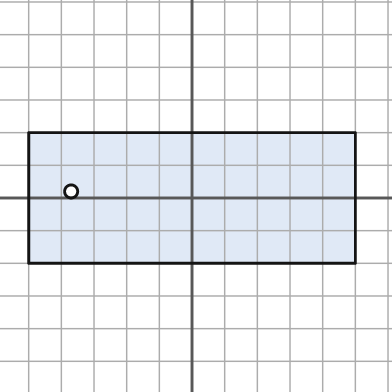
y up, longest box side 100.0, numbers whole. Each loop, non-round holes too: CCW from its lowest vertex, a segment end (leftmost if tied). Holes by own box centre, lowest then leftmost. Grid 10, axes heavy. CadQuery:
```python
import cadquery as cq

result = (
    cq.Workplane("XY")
    .moveTo(-50.0, -20.0)
    .lineTo(50.0, -20.0)
    .lineTo(50.0, 20.0)
    .lineTo(-50.0, 20.0)
    .close()
    .moveTo(-37.0, 2.0)
    .circle(2.0)
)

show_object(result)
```